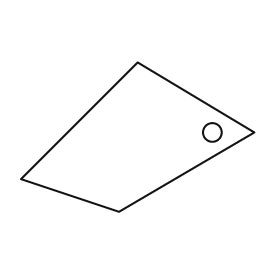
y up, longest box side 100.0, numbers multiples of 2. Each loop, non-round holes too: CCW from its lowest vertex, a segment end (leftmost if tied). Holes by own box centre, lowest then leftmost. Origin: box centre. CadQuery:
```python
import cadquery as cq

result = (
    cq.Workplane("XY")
    .moveTo(-8.0, -32.0)
    .lineTo(50.0, 2.0)
    .lineTo(0.0, 32.0)
    .lineTo(-50.0, -18.0)
    .close()
    .moveTo(32.0, 2.0)
    .circle(4.0)
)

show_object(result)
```